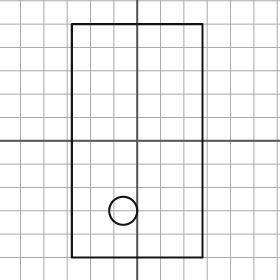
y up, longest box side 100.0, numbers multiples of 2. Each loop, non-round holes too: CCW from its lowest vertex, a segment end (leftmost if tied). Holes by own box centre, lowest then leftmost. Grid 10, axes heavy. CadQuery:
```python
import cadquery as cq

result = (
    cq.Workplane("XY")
    .moveTo(-28.0, -50.0)
    .lineTo(28.0, -50.0)
    .lineTo(28.0, 50.0)
    .lineTo(-28.0, 50.0)
    .close()
    .moveTo(-6.0, -30.0)
    .circle(6.0)
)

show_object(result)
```